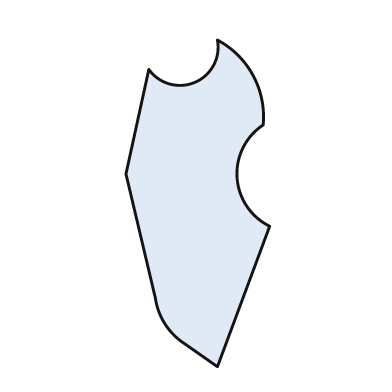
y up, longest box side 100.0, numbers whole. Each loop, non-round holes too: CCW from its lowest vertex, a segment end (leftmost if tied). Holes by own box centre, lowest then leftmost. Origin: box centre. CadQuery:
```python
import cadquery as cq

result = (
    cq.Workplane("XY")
    .moveTo(6.0, -50.0)
    .lineTo(22.0, -7.0)
    .threePointArc((12.0, 8.0), (20.0, 24.0))
    .threePointArc((17.0, 39.0), (6.0, 50.0))
    .threePointArc((-1.0, 37.0), (-15.0, 41.0))
    .lineTo(-22.0, 9.0)
    .lineTo(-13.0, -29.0)
    .threePointArc((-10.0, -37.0), (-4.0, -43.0))
    .close()
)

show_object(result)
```